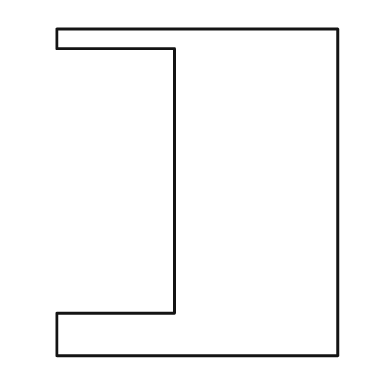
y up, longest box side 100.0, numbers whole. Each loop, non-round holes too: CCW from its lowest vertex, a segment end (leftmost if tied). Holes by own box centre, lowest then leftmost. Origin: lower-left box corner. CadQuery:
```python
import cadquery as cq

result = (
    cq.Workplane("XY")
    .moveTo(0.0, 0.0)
    .lineTo(86.0, 0.0)
    .lineTo(86.0, 100.0)
    .lineTo(0.0, 100.0)
    .lineTo(0.0, 94.0)
    .lineTo(36.0, 94.0)
    .lineTo(36.0, 13.0)
    .lineTo(0.0, 13.0)
    .close()
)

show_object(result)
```